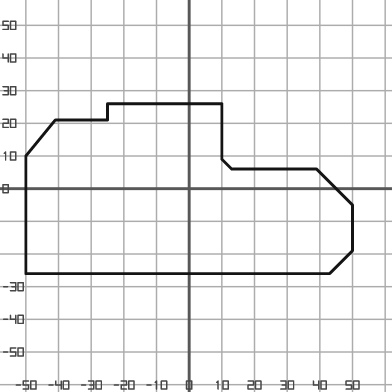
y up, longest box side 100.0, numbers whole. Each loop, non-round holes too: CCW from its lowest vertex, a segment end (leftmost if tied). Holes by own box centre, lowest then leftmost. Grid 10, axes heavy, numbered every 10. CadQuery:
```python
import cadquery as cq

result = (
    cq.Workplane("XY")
    .moveTo(-50.0, -26.0)
    .lineTo(43.0, -26.0)
    .lineTo(50.0, -19.0)
    .lineTo(50.0, -5.0)
    .lineTo(39.0, 6.0)
    .lineTo(13.0, 6.0)
    .lineTo(10.0, 9.0)
    .lineTo(10.0, 26.0)
    .lineTo(-25.0, 26.0)
    .lineTo(-25.0, 21.0)
    .lineTo(-41.0, 21.0)
    .lineTo(-50.0, 10.0)
    .close()
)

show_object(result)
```